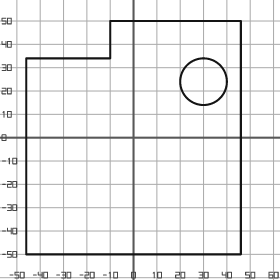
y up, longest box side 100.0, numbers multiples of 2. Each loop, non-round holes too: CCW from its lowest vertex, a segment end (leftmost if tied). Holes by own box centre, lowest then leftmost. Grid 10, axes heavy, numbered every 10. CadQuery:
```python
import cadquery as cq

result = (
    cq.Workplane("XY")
    .moveTo(-46.0, -50.0)
    .lineTo(46.0, -50.0)
    .lineTo(46.0, 50.0)
    .lineTo(-10.0, 50.0)
    .lineTo(-10.0, 34.0)
    .lineTo(-46.0, 34.0)
    .close()
    .moveTo(30.0, 24.0)
    .circle(10.0)
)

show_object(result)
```